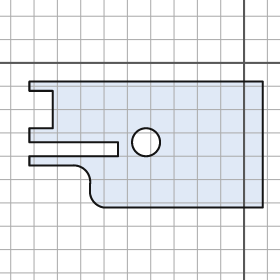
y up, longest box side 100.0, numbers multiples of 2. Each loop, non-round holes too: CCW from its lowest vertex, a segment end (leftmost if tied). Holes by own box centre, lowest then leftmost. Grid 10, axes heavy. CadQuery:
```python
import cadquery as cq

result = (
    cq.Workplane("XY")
    .moveTo(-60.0, -62.0)
    .lineTo(8.0, -62.0)
    .lineTo(8.0, -8.0)
    .lineTo(-92.0, -8.0)
    .lineTo(-92.0, -12.0)
    .lineTo(-82.0, -12.0)
    .lineTo(-82.0, -28.0)
    .lineTo(-92.0, -28.0)
    .lineTo(-92.0, -34.0)
    .lineTo(-54.0, -34.0)
    .lineTo(-54.0, -40.0)
    .lineTo(-92.0, -40.0)
    .lineTo(-92.0, -44.0)
    .lineTo(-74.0, -44.0)
    .threePointArc((-68.0, -46.0), (-66.0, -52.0))
    .lineTo(-66.0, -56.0)
    .threePointArc((-64.0, -60.0), (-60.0, -62.0))
    .close()
    .moveTo(-42.0, -34.0)
    .circle(6.0)
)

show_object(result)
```